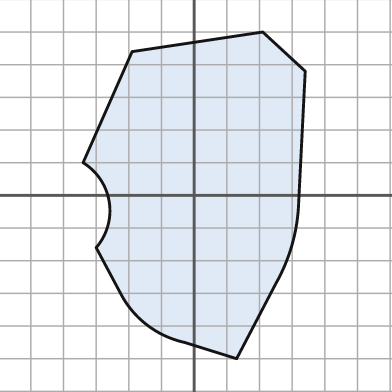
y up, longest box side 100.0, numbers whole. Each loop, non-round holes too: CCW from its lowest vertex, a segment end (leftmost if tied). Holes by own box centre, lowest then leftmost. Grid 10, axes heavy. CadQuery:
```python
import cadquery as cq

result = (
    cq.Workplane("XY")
    .moveTo(13.0, -50.0)
    .lineTo(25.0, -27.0)
    .threePointArc((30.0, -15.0), (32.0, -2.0))
    .lineTo(34.0, 38.0)
    .lineTo(21.0, 50.0)
    .lineTo(-19.0, 44.0)
    .lineTo(-34.0, 10.0)
    .threePointArc((-26.0, -2.0), (-30.0, -16.0))
    .lineTo(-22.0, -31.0)
    .threePointArc((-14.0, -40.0), (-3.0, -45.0))
    .close()
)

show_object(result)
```